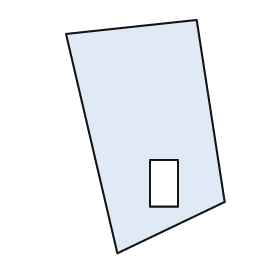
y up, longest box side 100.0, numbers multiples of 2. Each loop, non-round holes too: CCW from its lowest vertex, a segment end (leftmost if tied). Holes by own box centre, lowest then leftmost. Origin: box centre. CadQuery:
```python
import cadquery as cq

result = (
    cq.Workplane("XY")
    .moveTo(-12.0, -50.0)
    .lineTo(34.0, -28.0)
    .lineTo(22.0, 50.0)
    .lineTo(-34.0, 44.0)
    .close()
    .moveTo(2.0, -30.0)
    .lineTo(14.0, -30.0)
    .lineTo(14.0, -10.0)
    .lineTo(2.0, -10.0)
    .close()
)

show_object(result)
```